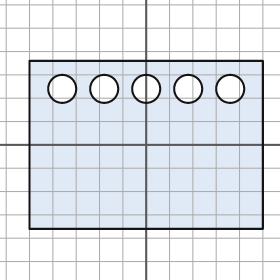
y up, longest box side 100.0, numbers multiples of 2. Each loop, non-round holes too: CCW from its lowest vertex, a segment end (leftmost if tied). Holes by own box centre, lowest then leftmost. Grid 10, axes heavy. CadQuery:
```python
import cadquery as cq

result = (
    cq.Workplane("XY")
    .moveTo(-50.0, -36.0)
    .lineTo(50.0, -36.0)
    .lineTo(50.0, 36.0)
    .lineTo(-50.0, 36.0)
    .close()
    .moveTo(-36.0, 24.0)
    .circle(6.0)
    .moveTo(-18.0, 24.0)
    .circle(6.0)
    .moveTo(0.0, 24.0)
    .circle(6.0)
    .moveTo(18.0, 24.0)
    .circle(6.0)
    .moveTo(36.0, 24.0)
    .circle(6.0)
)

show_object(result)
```